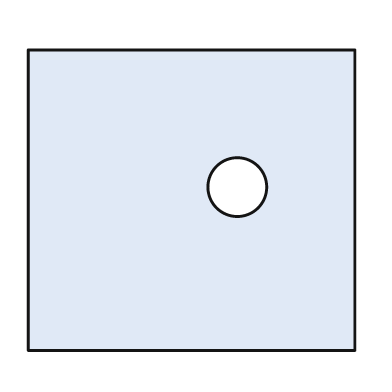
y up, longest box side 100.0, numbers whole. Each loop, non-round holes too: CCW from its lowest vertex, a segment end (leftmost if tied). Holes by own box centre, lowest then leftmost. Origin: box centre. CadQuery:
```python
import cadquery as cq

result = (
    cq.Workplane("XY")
    .moveTo(-50.0, -46.0)
    .lineTo(50.0, -46.0)
    .lineTo(50.0, 46.0)
    .lineTo(-50.0, 46.0)
    .close()
    .moveTo(14.0, 4.0)
    .circle(9.0)
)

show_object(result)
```